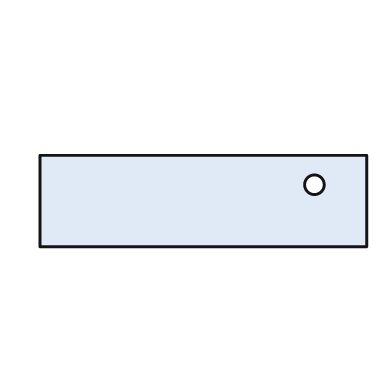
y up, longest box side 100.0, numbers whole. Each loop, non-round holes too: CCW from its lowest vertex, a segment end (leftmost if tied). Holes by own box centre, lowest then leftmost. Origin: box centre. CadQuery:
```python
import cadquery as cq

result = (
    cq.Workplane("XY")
    .moveTo(-50.0, -14.0)
    .lineTo(50.0, -14.0)
    .lineTo(50.0, 14.0)
    .lineTo(-50.0, 14.0)
    .close()
    .moveTo(34.0, 5.0)
    .circle(3.0)
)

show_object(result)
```